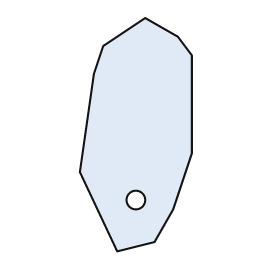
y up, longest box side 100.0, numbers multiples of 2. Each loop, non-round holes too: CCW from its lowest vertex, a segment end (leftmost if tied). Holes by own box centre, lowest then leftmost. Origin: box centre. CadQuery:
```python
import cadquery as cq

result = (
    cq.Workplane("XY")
    .moveTo(-8.0, -50.0)
    .lineTo(8.0, -46.0)
    .lineTo(16.0, -32.0)
    .lineTo(24.0, -8.0)
    .lineTo(24.0, 34.0)
    .lineTo(18.0, 42.0)
    .lineTo(4.0, 50.0)
    .lineTo(-14.0, 38.0)
    .lineTo(-18.0, 26.0)
    .lineTo(-24.0, -16.0)
    .close()
    .moveTo(0.0, -28.0)
    .circle(4.0)
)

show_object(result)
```